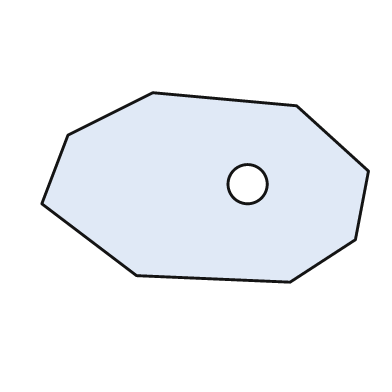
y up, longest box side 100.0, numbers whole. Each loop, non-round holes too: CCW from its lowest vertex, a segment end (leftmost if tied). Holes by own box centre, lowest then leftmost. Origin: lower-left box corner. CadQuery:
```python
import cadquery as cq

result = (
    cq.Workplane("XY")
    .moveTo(76.0, 0.0)
    .lineTo(96.0, 13.0)
    .lineTo(100.0, 34.0)
    .lineTo(78.0, 54.0)
    .lineTo(34.0, 58.0)
    .lineTo(8.0, 45.0)
    .lineTo(0.0, 24.0)
    .lineTo(29.0, 2.0)
    .close()
    .moveTo(63.0, 30.0)
    .circle(6.0)
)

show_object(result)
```